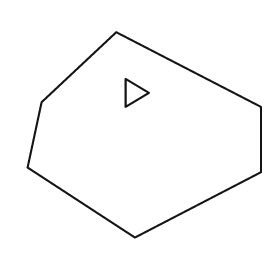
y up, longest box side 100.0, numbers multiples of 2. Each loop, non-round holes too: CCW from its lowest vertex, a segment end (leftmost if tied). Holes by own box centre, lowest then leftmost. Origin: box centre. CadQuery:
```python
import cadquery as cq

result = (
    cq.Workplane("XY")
    .moveTo(-4.0, -44.0)
    .lineTo(50.0, -16.0)
    .lineTo(50.0, 12.0)
    .lineTo(-12.0, 44.0)
    .lineTo(-44.0, 14.0)
    .lineTo(-50.0, -14.0)
    .close()
    .moveTo(-8.0, 12.0)
    .lineTo(2.0, 18.0)
    .lineTo(-8.0, 24.0)
    .close()
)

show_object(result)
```